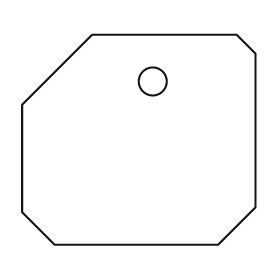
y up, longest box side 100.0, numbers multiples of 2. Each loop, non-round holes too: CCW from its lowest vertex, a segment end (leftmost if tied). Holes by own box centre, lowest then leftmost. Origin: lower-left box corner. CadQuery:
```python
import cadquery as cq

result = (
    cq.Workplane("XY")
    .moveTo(14.0, 0.0)
    .lineTo(84.0, 0.0)
    .lineTo(100.0, 16.0)
    .lineTo(100.0, 82.0)
    .lineTo(92.0, 90.0)
    .lineTo(30.0, 90.0)
    .lineTo(0.0, 60.0)
    .lineTo(0.0, 14.0)
    .close()
    .moveTo(56.0, 70.0)
    .circle(6.0)
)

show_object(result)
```